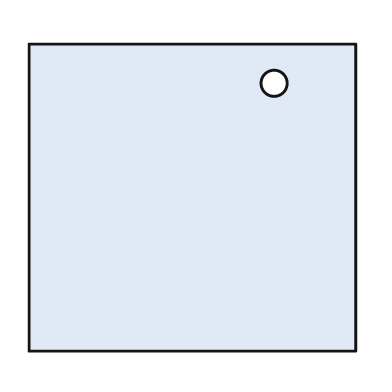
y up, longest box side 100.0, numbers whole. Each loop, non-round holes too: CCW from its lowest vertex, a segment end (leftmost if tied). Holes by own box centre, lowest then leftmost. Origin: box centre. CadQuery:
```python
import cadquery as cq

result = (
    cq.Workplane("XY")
    .moveTo(-50.0, -47.0)
    .lineTo(50.0, -47.0)
    .lineTo(50.0, 47.0)
    .lineTo(-50.0, 47.0)
    .close()
    .moveTo(25.0, 35.0)
    .circle(4.0)
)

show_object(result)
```